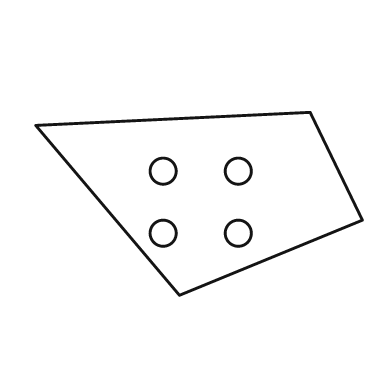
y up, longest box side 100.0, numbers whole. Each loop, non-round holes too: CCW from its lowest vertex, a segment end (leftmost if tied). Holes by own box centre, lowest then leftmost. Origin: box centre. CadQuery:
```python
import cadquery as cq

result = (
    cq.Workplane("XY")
    .moveTo(-6.0, -28.0)
    .lineTo(50.0, -5.0)
    .lineTo(34.0, 28.0)
    .lineTo(-50.0, 24.0)
    .close()
    .moveTo(-11.0, -9.0)
    .circle(4.0)
    .moveTo(12.0, -9.0)
    .circle(4.0)
    .moveTo(-11.0, 10.0)
    .circle(4.0)
    .moveTo(12.0, 10.0)
    .circle(4.0)
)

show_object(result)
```